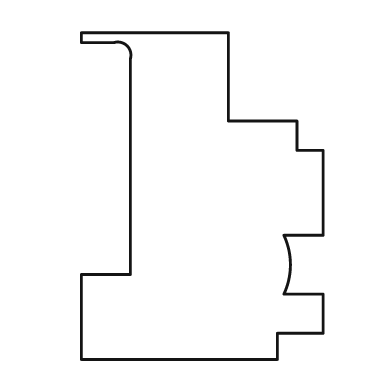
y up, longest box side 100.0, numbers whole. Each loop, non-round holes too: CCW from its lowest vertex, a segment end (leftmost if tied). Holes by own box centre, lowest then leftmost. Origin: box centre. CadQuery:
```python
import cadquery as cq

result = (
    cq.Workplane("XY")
    .moveTo(-37.0, -50.0)
    .lineTo(23.0, -50.0)
    .lineTo(23.0, -42.0)
    .lineTo(37.0, -42.0)
    .lineTo(37.0, -30.0)
    .lineTo(25.0, -30.0)
    .threePointArc((27.0, -21.0), (25.0, -12.0))
    .lineTo(37.0, -12.0)
    .lineTo(37.0, 14.0)
    .lineTo(29.0, 14.0)
    .lineTo(29.0, 23.0)
    .lineTo(8.0, 23.0)
    .lineTo(8.0, 50.0)
    .lineTo(-37.0, 50.0)
    .lineTo(-37.0, 47.0)
    .lineTo(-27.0, 47.0)
    .threePointArc((-23.0, 46.0), (-22.0, 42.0))
    .lineTo(-22.0, -24.0)
    .lineTo(-37.0, -24.0)
    .close()
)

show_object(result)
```